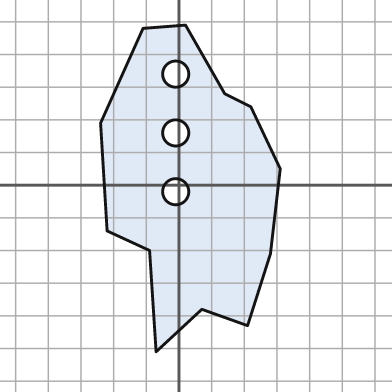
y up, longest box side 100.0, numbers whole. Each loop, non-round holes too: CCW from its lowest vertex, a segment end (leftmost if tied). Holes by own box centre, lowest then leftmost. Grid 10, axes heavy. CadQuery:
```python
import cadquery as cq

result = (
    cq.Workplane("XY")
    .moveTo(-7.0, -51.0)
    .lineTo(7.0, -38.0)
    .lineTo(21.0, -43.0)
    .lineTo(28.0, -21.0)
    .lineTo(31.0, 5.0)
    .lineTo(22.0, 24.0)
    .lineTo(14.0, 28.0)
    .lineTo(2.0, 49.0)
    .lineTo(-11.0, 48.0)
    .lineTo(-24.0, 19.0)
    .lineTo(-22.0, -14.0)
    .lineTo(-9.0, -20.0)
    .close()
    .moveTo(-1.0, -2.0)
    .circle(4.0)
    .moveTo(-1.0, 16.0)
    .circle(4.0)
    .moveTo(-1.0, 34.0)
    .circle(4.0)
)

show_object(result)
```